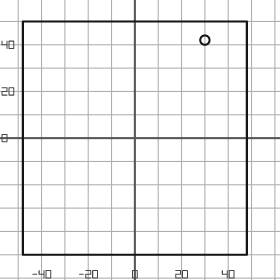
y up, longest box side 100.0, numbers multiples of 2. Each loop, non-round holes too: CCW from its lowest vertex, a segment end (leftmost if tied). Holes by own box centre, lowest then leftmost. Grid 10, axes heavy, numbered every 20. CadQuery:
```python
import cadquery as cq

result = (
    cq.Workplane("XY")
    .moveTo(-48.0, -50.0)
    .lineTo(48.0, -50.0)
    .lineTo(48.0, 50.0)
    .lineTo(-48.0, 50.0)
    .close()
    .moveTo(30.0, 42.0)
    .circle(2.0)
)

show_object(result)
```